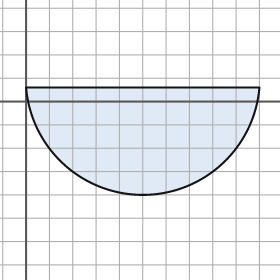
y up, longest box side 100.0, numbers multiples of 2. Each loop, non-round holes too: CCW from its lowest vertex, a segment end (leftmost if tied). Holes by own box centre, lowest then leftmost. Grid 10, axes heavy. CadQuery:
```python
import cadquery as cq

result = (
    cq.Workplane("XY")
    .moveTo(0.0, 6.0)
    .threePointArc((50.0, -40.0), (100.0, 6.0))
    .close()
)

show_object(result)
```